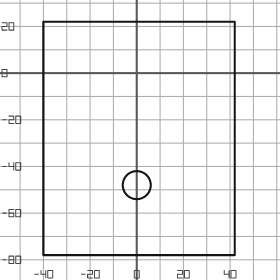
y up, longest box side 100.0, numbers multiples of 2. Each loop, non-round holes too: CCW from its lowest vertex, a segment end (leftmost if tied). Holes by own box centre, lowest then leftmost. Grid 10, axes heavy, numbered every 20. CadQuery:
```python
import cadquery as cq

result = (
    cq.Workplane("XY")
    .moveTo(-40.0, -78.0)
    .lineTo(42.0, -78.0)
    .lineTo(42.0, 22.0)
    .lineTo(-40.0, 22.0)
    .close()
    .moveTo(0.0, -48.0)
    .circle(6.0)
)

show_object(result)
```